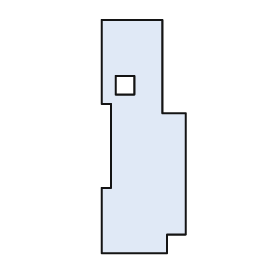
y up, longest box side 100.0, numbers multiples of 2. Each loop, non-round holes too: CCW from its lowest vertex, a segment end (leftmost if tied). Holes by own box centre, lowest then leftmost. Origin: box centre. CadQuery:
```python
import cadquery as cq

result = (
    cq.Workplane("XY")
    .moveTo(-18.0, -50.0)
    .lineTo(10.0, -50.0)
    .lineTo(10.0, -42.0)
    .lineTo(18.0, -42.0)
    .lineTo(18.0, 10.0)
    .lineTo(8.0, 10.0)
    .lineTo(8.0, 50.0)
    .lineTo(-18.0, 50.0)
    .lineTo(-18.0, 14.0)
    .lineTo(-14.0, 14.0)
    .lineTo(-14.0, -22.0)
    .lineTo(-18.0, -22.0)
    .close()
    .moveTo(-12.0, 18.0)
    .lineTo(-4.0, 18.0)
    .lineTo(-4.0, 26.0)
    .lineTo(-12.0, 26.0)
    .close()
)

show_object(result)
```